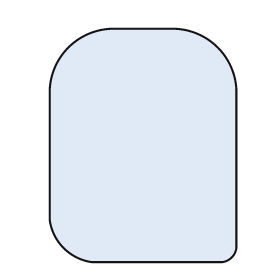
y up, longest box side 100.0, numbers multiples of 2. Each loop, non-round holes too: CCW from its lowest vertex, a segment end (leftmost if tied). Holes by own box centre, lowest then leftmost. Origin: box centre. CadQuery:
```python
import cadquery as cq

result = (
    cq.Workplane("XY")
    .moveTo(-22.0, -50.0)
    .lineTo(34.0, -50.0)
    .threePointArc((38.0, -48.0), (40.0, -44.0))
    .lineTo(40.0, 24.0)
    .threePointArc((32.0, 42.0), (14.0, 50.0))
    .lineTo(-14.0, 50.0)
    .threePointArc((-32.0, 42.0), (-40.0, 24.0))
    .lineTo(-40.0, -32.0)
    .threePointArc((-34.0, -44.0), (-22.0, -50.0))
    .close()
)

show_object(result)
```